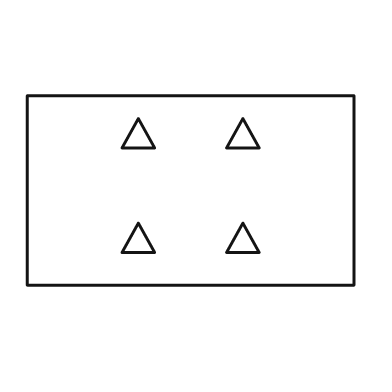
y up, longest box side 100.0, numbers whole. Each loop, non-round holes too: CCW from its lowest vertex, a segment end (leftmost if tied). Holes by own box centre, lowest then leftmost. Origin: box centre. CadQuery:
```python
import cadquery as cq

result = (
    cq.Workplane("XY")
    .moveTo(-50.0, -29.0)
    .lineTo(50.0, -29.0)
    .lineTo(50.0, 29.0)
    .lineTo(-50.0, 29.0)
    .close()
    .moveTo(-21.0, -19.0)
    .lineTo(-11.0, -19.0)
    .lineTo(-16.0, -10.0)
    .close()
    .moveTo(11.0, -19.0)
    .lineTo(21.0, -19.0)
    .lineTo(16.0, -10.0)
    .close()
    .moveTo(-21.0, 13.0)
    .lineTo(-11.0, 13.0)
    .lineTo(-16.0, 22.0)
    .close()
    .moveTo(11.0, 13.0)
    .lineTo(21.0, 13.0)
    .lineTo(16.0, 22.0)
    .close()
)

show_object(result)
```